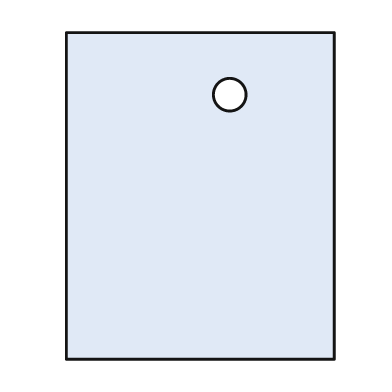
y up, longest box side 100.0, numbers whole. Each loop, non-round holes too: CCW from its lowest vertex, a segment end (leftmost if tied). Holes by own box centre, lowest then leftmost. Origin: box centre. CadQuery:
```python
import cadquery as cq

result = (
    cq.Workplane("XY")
    .moveTo(-41.0, -50.0)
    .lineTo(41.0, -50.0)
    .lineTo(41.0, 50.0)
    .lineTo(-41.0, 50.0)
    .close()
    .moveTo(9.0, 31.0)
    .circle(5.0)
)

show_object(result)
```